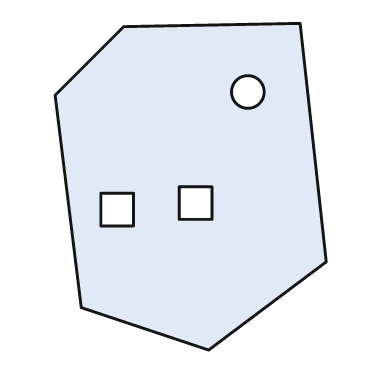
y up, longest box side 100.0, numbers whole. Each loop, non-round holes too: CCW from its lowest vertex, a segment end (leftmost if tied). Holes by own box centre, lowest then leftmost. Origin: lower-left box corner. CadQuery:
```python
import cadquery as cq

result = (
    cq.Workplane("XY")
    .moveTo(47.0, 0.0)
    .lineTo(83.0, 27.0)
    .lineTo(75.0, 100.0)
    .lineTo(21.0, 99.0)
    .lineTo(0.0, 78.0)
    .lineTo(8.0, 13.0)
    .close()
    .moveTo(14.0, 38.0)
    .lineTo(24.0, 38.0)
    .lineTo(24.0, 48.0)
    .lineTo(14.0, 48.0)
    .close()
    .moveTo(38.0, 40.0)
    .lineTo(48.0, 40.0)
    .lineTo(48.0, 50.0)
    .lineTo(38.0, 50.0)
    .close()
    .moveTo(59.0, 79.0)
    .circle(5.0)
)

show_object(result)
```